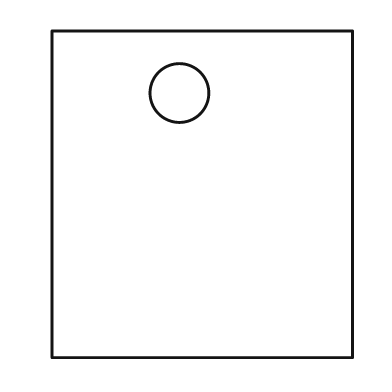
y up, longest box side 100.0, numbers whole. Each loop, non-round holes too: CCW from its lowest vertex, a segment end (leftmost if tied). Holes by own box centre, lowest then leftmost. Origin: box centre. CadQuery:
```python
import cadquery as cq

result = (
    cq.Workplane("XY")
    .moveTo(-46.0, -50.0)
    .lineTo(46.0, -50.0)
    .lineTo(46.0, 50.0)
    .lineTo(-46.0, 50.0)
    .close()
    .moveTo(-7.0, 31.0)
    .circle(9.0)
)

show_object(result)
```